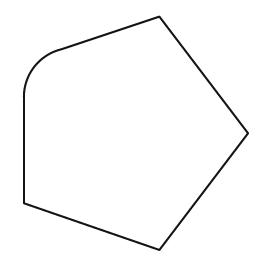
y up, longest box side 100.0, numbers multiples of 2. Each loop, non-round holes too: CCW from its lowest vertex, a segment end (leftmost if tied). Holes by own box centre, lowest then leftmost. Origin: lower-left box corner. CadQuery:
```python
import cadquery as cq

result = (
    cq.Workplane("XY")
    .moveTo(58.0, 0.0)
    .lineTo(96.0, 50.0)
    .lineTo(58.0, 100.0)
    .lineTo(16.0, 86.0)
    .threePointArc((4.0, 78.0), (0.0, 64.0))
    .lineTo(0.0, 20.0)
    .close()
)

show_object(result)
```